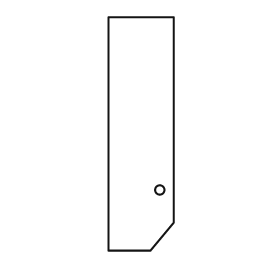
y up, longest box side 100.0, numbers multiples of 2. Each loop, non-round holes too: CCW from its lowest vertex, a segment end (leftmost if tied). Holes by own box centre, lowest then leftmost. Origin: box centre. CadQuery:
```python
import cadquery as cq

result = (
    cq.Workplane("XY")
    .moveTo(-14.0, -50.0)
    .lineTo(4.0, -50.0)
    .lineTo(14.0, -38.0)
    .lineTo(14.0, 50.0)
    .lineTo(-14.0, 50.0)
    .close()
    .moveTo(8.0, -24.0)
    .circle(2.0)
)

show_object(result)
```